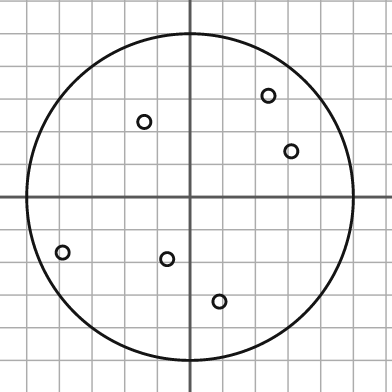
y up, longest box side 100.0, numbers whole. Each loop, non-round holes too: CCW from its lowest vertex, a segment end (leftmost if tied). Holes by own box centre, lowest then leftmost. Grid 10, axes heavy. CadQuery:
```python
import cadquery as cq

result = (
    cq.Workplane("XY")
    .moveTo(0.0, 0.0)
    .circle(50.0)
    .moveTo(9.0, -32.0)
    .circle(2.0)
    .moveTo(-7.0, -19.0)
    .circle(2.0)
    .moveTo(-39.0, -17.0)
    .circle(2.0)
    .moveTo(31.0, 14.0)
    .circle(2.0)
    .moveTo(-14.0, 23.0)
    .circle(2.0)
    .moveTo(24.0, 31.0)
    .circle(2.0)
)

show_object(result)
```